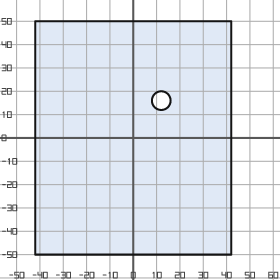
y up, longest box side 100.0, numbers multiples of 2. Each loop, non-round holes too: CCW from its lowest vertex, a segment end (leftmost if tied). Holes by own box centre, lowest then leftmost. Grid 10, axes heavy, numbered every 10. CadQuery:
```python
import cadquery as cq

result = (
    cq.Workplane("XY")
    .moveTo(-42.0, -50.0)
    .lineTo(42.0, -50.0)
    .lineTo(42.0, 50.0)
    .lineTo(-42.0, 50.0)
    .close()
    .moveTo(12.0, 16.0)
    .circle(4.0)
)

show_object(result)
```